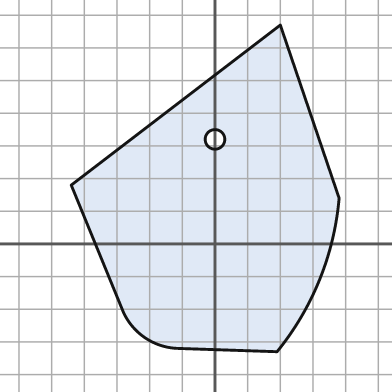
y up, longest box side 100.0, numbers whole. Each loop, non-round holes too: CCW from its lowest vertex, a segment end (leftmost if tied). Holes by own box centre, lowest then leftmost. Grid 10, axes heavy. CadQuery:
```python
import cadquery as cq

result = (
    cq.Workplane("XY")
    .moveTo(19.0, -33.0)
    .threePointArc((32.0, -11.0), (38.0, 14.0))
    .lineTo(20.0, 67.0)
    .lineTo(-44.0, 18.0)
    .lineTo(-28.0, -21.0)
    .threePointArc((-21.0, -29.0), (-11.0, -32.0))
    .close()
    .moveTo(0.0, 32.0)
    .circle(3.0)
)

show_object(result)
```